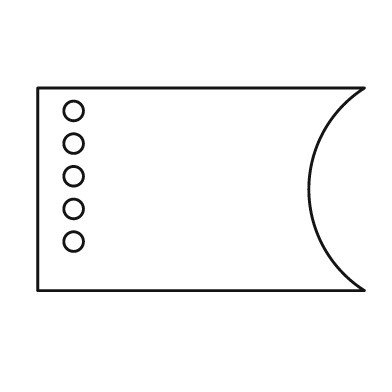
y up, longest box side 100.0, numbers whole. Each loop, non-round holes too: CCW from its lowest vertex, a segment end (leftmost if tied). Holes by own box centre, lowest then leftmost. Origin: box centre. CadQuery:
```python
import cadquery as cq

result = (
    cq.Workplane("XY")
    .moveTo(-50.0, -31.0)
    .lineTo(50.0, -31.0)
    .threePointArc((33.0, 0.0), (50.0, 31.0))
    .lineTo(-50.0, 31.0)
    .close()
    .moveTo(-39.0, -16.0)
    .circle(3.0)
    .moveTo(-39.0, -6.0)
    .circle(3.0)
    .moveTo(-39.0, 4.0)
    .circle(3.0)
    .moveTo(-39.0, 14.0)
    .circle(3.0)
    .moveTo(-39.0, 24.0)
    .circle(3.0)
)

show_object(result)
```